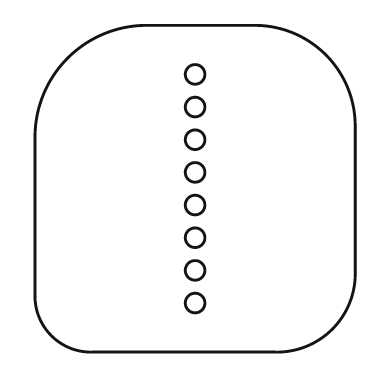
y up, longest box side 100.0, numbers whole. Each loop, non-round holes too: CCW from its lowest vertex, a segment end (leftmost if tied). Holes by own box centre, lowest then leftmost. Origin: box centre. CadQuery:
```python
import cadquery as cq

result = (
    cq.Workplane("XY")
    .moveTo(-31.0, -50.0)
    .lineTo(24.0, -50.0)
    .threePointArc((42.0, -43.0), (49.0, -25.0))
    .lineTo(49.0, 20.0)
    .threePointArc((40.0, 41.0), (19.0, 50.0))
    .lineTo(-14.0, 50.0)
    .threePointArc((-39.0, 40.0), (-49.0, 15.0))
    .lineTo(-49.0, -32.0)
    .threePointArc((-44.0, -45.0), (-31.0, -50.0))
    .close()
    .moveTo(0.0, -35.0)
    .circle(3.0)
    .moveTo(0.0, -25.0)
    .circle(3.0)
    .moveTo(0.0, -15.0)
    .circle(3.0)
    .moveTo(0.0, -5.0)
    .circle(3.0)
    .moveTo(0.0, 5.0)
    .circle(3.0)
    .moveTo(0.0, 15.0)
    .circle(3.0)
    .moveTo(0.0, 25.0)
    .circle(3.0)
    .moveTo(0.0, 35.0)
    .circle(3.0)
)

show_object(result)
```